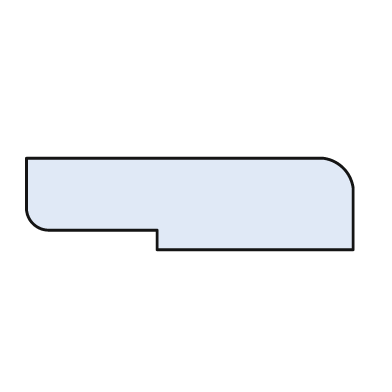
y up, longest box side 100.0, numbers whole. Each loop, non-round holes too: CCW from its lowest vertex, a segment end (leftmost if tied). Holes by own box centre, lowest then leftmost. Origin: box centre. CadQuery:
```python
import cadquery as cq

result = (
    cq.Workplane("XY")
    .moveTo(-10.0, -14.0)
    .lineTo(50.0, -14.0)
    .lineTo(50.0, 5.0)
    .threePointArc((47.0, 11.0), (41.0, 14.0))
    .lineTo(-50.0, 14.0)
    .lineTo(-50.0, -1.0)
    .threePointArc((-48.0, -6.0), (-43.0, -8.0))
    .lineTo(-10.0, -8.0)
    .close()
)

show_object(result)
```